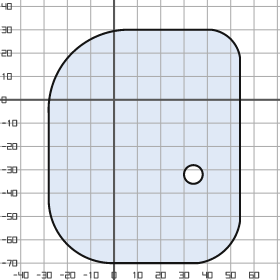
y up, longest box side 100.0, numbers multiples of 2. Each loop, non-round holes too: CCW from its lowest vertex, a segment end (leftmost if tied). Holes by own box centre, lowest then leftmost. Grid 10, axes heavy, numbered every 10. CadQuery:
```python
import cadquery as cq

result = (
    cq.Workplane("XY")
    .moveTo(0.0, -70.0)
    .lineTo(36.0, -70.0)
    .threePointArc((48.0, -64.0), (54.0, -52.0))
    .lineTo(54.0, 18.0)
    .threePointArc((50.0, 26.0), (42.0, 30.0))
    .lineTo(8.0, 30.0)
    .threePointArc((-18.0, 20.0), (-28.0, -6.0))
    .lineTo(-28.0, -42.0)
    .threePointArc((-20.0, -62.0), (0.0, -70.0))
    .close()
    .moveTo(34.0, -32.0)
    .circle(4.0)
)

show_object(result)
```